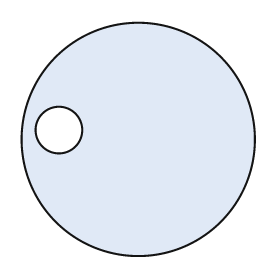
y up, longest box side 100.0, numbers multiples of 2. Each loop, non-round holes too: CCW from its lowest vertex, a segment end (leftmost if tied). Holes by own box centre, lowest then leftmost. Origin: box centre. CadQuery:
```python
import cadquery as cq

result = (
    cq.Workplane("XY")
    .moveTo(0.0, 0.0)
    .circle(50.0)
    .moveTo(-34.0, 4.0)
    .circle(10.0)
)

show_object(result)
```